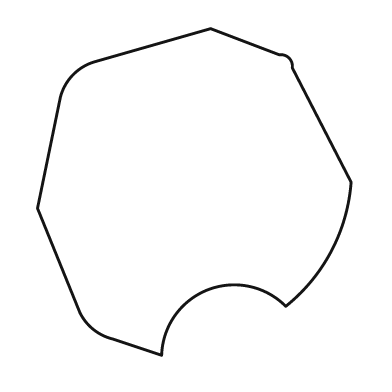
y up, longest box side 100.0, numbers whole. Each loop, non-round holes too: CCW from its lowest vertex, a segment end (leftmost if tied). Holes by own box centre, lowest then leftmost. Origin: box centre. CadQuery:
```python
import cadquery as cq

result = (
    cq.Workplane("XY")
    .moveTo(-10.0, -50.0)
    .threePointArc((4.0, -30.0), (28.0, -35.0))
    .threePointArc((42.0, -18.0), (48.0, 3.0))
    .lineTo(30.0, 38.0)
    .threePointArc((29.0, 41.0), (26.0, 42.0))
    .lineTo(5.0, 50.0)
    .lineTo(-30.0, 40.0)
    .threePointArc((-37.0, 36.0), (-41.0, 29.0))
    .lineTo(-48.0, -5.0)
    .lineTo(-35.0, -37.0)
    .threePointArc((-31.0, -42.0), (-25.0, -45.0))
    .close()
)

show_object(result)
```